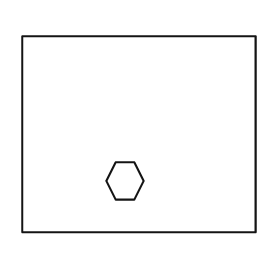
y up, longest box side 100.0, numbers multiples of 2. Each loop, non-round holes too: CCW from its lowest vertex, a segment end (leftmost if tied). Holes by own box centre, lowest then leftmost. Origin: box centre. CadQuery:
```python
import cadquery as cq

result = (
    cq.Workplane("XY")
    .moveTo(-50.0, -42.0)
    .lineTo(50.0, -42.0)
    .lineTo(50.0, 42.0)
    .lineTo(-50.0, 42.0)
    .close()
    .moveTo(-10.0, -28.0)
    .lineTo(-2.0, -28.0)
    .lineTo(2.0, -20.0)
    .lineTo(-2.0, -12.0)
    .lineTo(-10.0, -12.0)
    .lineTo(-14.0, -20.0)
    .close()
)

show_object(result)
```